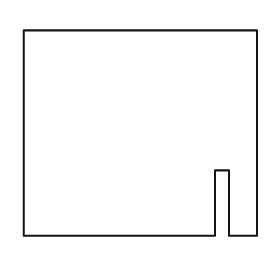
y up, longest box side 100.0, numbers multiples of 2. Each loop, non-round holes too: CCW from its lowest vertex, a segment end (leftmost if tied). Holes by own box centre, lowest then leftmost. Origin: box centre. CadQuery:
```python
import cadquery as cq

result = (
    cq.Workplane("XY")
    .moveTo(-50.0, -44.0)
    .lineTo(32.0, -44.0)
    .lineTo(32.0, -16.0)
    .lineTo(38.0, -16.0)
    .lineTo(38.0, -44.0)
    .lineTo(50.0, -44.0)
    .lineTo(50.0, 44.0)
    .lineTo(-50.0, 44.0)
    .close()
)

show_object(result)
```